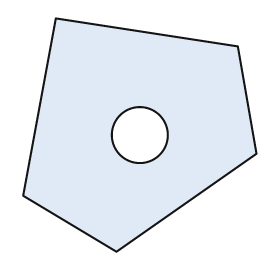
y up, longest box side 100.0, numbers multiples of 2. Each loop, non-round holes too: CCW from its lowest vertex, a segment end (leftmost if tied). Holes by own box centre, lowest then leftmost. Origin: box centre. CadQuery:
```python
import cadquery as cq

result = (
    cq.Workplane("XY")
    .moveTo(-10.0, -50.0)
    .lineTo(50.0, -8.0)
    .lineTo(42.0, 38.0)
    .lineTo(-36.0, 50.0)
    .lineTo(-50.0, -26.0)
    .close()
    .moveTo(0.0, 0.0)
    .circle(12.0)
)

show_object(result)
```